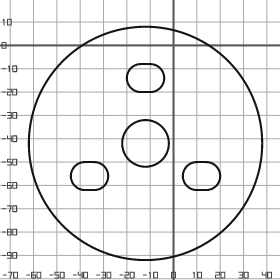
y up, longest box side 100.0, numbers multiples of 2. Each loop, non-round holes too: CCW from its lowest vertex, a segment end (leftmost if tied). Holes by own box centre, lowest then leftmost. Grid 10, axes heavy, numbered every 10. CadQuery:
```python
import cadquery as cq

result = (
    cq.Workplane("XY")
    .moveTo(-12.0, -42.0)
    .circle(50.0)
    .moveTo(-38.0, -62.0)
    .lineTo(-34.0, -62.0)
    .threePointArc((-28.0, -56.0), (-34.0, -50.0))
    .lineTo(-38.0, -50.0)
    .threePointArc((-44.0, -56.0), (-38.0, -62.0))
    .close()
    .moveTo(10.0, -62.0)
    .lineTo(14.0, -62.0)
    .threePointArc((20.0, -56.0), (14.0, -50.0))
    .lineTo(10.0, -50.0)
    .threePointArc((4.0, -56.0), (10.0, -62.0))
    .close()
    .moveTo(-12.0, -42.0)
    .circle(10.0)
    .moveTo(-14.0, -20.0)
    .lineTo(-10.0, -20.0)
    .threePointArc((-4.0, -14.0), (-10.0, -8.0))
    .lineTo(-14.0, -8.0)
    .threePointArc((-20.0, -14.0), (-14.0, -20.0))
    .close()
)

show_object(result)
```